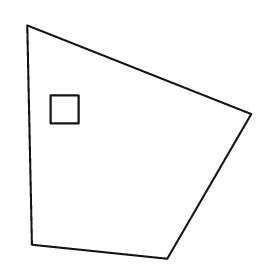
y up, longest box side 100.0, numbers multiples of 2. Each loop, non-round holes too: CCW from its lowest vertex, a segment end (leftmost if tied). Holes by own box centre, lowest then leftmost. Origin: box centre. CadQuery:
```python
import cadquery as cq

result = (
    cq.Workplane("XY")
    .moveTo(12.0, -50.0)
    .lineTo(48.0, 12.0)
    .lineTo(-48.0, 50.0)
    .lineTo(-46.0, -44.0)
    .close()
    .moveTo(-38.0, 8.0)
    .lineTo(-26.0, 8.0)
    .lineTo(-26.0, 20.0)
    .lineTo(-38.0, 20.0)
    .close()
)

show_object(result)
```